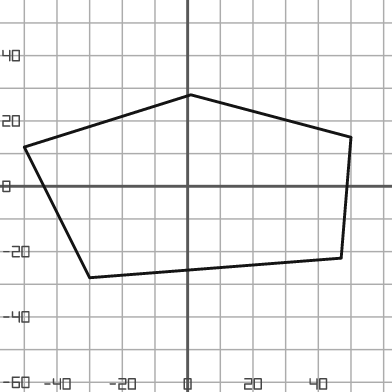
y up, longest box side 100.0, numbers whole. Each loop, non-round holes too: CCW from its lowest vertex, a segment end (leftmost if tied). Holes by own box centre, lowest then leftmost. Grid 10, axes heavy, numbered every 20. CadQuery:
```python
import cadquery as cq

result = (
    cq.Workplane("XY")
    .moveTo(-30.0, -28.0)
    .lineTo(47.0, -22.0)
    .lineTo(50.0, 15.0)
    .lineTo(1.0, 28.0)
    .lineTo(-50.0, 12.0)
    .close()
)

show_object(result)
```